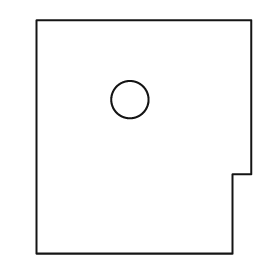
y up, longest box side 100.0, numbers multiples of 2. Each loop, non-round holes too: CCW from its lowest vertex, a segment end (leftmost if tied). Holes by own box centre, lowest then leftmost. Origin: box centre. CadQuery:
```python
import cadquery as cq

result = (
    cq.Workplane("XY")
    .moveTo(-46.0, -50.0)
    .lineTo(38.0, -50.0)
    .lineTo(38.0, -16.0)
    .lineTo(46.0, -16.0)
    .lineTo(46.0, 50.0)
    .lineTo(-46.0, 50.0)
    .close()
    .moveTo(-6.0, 16.0)
    .circle(8.0)
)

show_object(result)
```